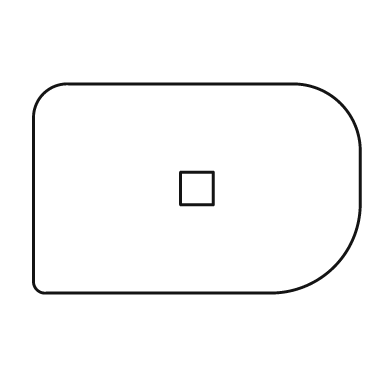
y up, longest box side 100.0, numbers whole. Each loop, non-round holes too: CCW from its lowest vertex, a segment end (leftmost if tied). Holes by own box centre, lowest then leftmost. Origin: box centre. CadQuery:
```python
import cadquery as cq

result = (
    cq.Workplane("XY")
    .moveTo(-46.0, -32.0)
    .lineTo(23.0, -32.0)
    .threePointArc((42.0, -24.0), (50.0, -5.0))
    .lineTo(50.0, 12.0)
    .threePointArc((44.0, 26.0), (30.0, 32.0))
    .lineTo(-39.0, 32.0)
    .threePointArc((-47.0, 29.0), (-50.0, 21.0))
    .lineTo(-50.0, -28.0)
    .threePointArc((-49.0, -31.0), (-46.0, -32.0))
    .close()
    .moveTo(-5.0, -5.0)
    .lineTo(5.0, -5.0)
    .lineTo(5.0, 5.0)
    .lineTo(-5.0, 5.0)
    .close()
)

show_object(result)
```